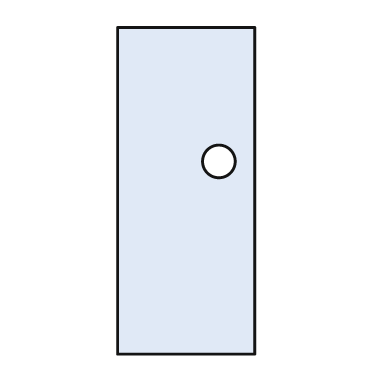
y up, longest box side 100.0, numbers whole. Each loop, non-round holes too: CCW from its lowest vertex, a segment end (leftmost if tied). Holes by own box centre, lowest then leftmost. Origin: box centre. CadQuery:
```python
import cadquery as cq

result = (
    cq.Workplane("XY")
    .moveTo(-21.0, -50.0)
    .lineTo(21.0, -50.0)
    .lineTo(21.0, 50.0)
    .lineTo(-21.0, 50.0)
    .close()
    .moveTo(10.0, 9.0)
    .circle(5.0)
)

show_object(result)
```